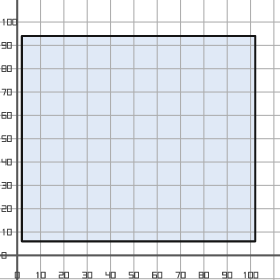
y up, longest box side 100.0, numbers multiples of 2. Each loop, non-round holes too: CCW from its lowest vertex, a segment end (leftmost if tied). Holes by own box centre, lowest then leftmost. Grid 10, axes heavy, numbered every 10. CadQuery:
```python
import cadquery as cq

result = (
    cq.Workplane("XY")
    .moveTo(2.0, 6.0)
    .lineTo(102.0, 6.0)
    .lineTo(102.0, 94.0)
    .lineTo(2.0, 94.0)
    .close()
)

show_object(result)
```